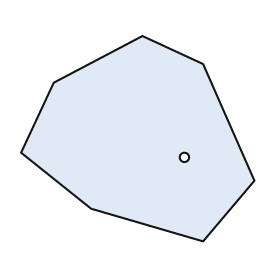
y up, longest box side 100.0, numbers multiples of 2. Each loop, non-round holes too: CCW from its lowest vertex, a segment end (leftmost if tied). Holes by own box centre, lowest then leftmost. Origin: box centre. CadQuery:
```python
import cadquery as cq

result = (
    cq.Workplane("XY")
    .moveTo(28.0, -44.0)
    .lineTo(50.0, -18.0)
    .lineTo(28.0, 32.0)
    .lineTo(2.0, 44.0)
    .lineTo(-36.0, 24.0)
    .lineTo(-50.0, -6.0)
    .lineTo(-20.0, -30.0)
    .close()
    .moveTo(20.0, -8.0)
    .circle(2.0)
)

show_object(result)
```